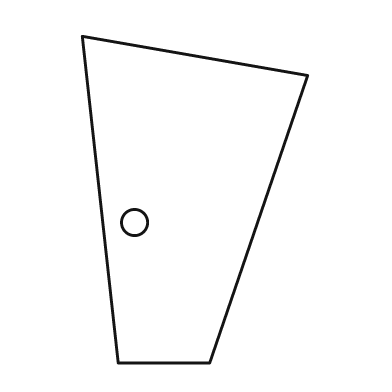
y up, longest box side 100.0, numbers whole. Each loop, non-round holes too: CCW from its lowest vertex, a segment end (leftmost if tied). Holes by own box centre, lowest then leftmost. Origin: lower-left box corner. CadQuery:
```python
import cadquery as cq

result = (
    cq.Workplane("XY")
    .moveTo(11.0, 0.0)
    .lineTo(39.0, 0.0)
    .lineTo(69.0, 88.0)
    .lineTo(0.0, 100.0)
    .close()
    .moveTo(16.0, 43.0)
    .circle(4.0)
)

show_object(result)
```